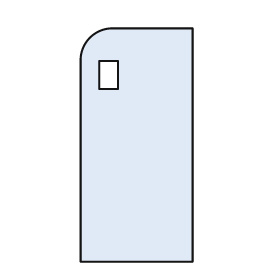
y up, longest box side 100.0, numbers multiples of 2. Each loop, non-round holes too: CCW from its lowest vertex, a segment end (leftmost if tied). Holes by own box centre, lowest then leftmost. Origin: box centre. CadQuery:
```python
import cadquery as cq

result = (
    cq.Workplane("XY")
    .moveTo(-24.0, -50.0)
    .lineTo(24.0, -50.0)
    .lineTo(24.0, 50.0)
    .lineTo(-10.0, 50.0)
    .threePointArc((-20.0, 46.0), (-24.0, 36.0))
    .close()
    .moveTo(-16.0, 24.0)
    .lineTo(-8.0, 24.0)
    .lineTo(-8.0, 36.0)
    .lineTo(-16.0, 36.0)
    .close()
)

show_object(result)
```